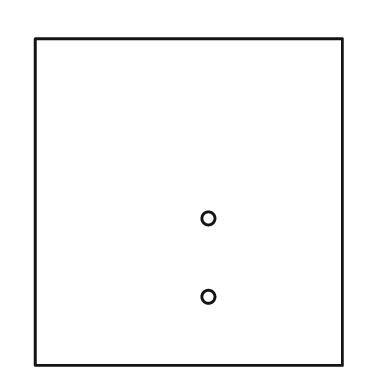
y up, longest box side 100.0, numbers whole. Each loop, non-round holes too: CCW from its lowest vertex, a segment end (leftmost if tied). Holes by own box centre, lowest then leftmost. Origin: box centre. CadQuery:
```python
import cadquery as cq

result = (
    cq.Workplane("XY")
    .moveTo(-47.0, -50.0)
    .lineTo(47.0, -50.0)
    .lineTo(47.0, 50.0)
    .lineTo(-47.0, 50.0)
    .close()
    .moveTo(6.0, -29.0)
    .circle(2.0)
    .moveTo(6.0, -5.0)
    .circle(2.0)
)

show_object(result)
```